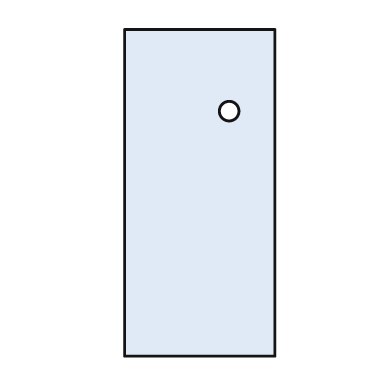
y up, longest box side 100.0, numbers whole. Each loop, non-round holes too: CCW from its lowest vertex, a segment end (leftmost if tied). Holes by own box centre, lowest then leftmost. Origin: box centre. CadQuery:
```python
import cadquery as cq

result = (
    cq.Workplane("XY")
    .moveTo(-23.0, -50.0)
    .lineTo(23.0, -50.0)
    .lineTo(23.0, 50.0)
    .lineTo(-23.0, 50.0)
    .close()
    .moveTo(9.0, 25.0)
    .circle(3.0)
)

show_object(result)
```